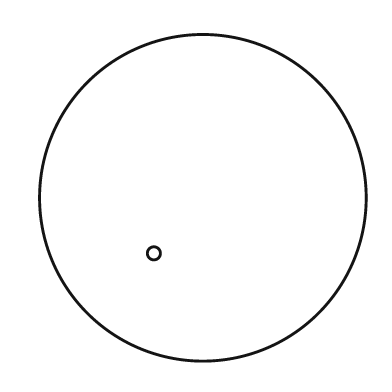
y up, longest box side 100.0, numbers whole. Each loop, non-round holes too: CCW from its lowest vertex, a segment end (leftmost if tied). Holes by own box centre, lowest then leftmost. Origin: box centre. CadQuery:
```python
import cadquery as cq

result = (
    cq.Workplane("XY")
    .moveTo(0.0, 0.0)
    .circle(50.0)
    .moveTo(-15.0, -17.0)
    .circle(2.0)
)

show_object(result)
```